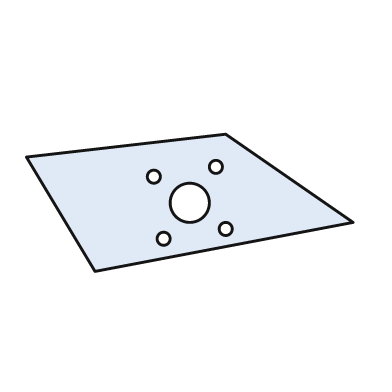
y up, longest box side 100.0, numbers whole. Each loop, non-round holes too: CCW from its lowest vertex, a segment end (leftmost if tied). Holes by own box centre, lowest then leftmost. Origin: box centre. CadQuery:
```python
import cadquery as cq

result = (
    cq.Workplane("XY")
    .moveTo(-29.0, -21.0)
    .lineTo(50.0, -6.0)
    .lineTo(11.0, 21.0)
    .lineTo(-50.0, 14.0)
    .close()
    .moveTo(-8.0, -11.0)
    .circle(2.0)
    .moveTo(11.0, -8.0)
    .circle(2.0)
    .moveTo(0.0, 0.0)
    .circle(6.0)
    .moveTo(-11.0, 8.0)
    .circle(2.0)
    .moveTo(8.0, 11.0)
    .circle(2.0)
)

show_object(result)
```